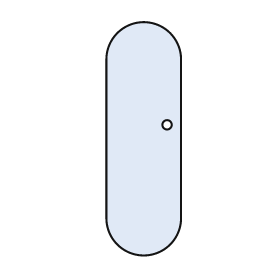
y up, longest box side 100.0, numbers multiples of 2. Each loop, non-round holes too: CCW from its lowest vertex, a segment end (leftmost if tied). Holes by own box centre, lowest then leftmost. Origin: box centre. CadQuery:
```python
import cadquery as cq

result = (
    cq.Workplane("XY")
    .moveTo(-16.0, -34.0)
    .threePointArc((0.0, -50.0), (16.0, -34.0))
    .lineTo(16.0, 34.0)
    .threePointArc((0.0, 50.0), (-16.0, 34.0))
    .close()
    .moveTo(10.0, 6.0)
    .circle(2.0)
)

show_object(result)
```